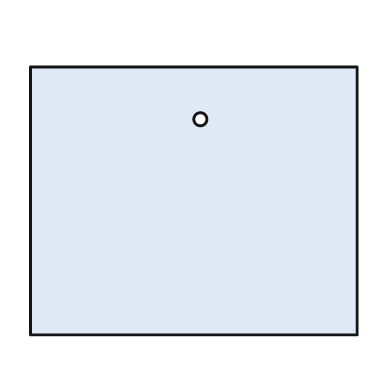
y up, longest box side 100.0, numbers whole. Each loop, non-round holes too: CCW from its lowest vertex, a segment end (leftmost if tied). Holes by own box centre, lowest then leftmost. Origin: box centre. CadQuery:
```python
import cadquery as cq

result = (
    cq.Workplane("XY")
    .moveTo(-50.0, -41.0)
    .lineTo(50.0, -41.0)
    .lineTo(50.0, 41.0)
    .lineTo(-50.0, 41.0)
    .close()
    .moveTo(2.0, 25.0)
    .circle(2.0)
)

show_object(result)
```